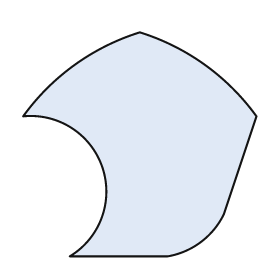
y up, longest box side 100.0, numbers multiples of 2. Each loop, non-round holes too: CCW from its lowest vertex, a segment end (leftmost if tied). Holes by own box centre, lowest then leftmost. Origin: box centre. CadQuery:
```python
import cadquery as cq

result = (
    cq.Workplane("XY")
    .moveTo(-30.0, -48.0)
    .lineTo(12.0, -48.0)
    .threePointArc((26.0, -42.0), (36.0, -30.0))
    .lineTo(50.0, 12.0)
    .threePointArc((28.0, 34.0), (0.0, 48.0))
    .threePointArc((-28.0, 34.0), (-50.0, 12.0))
    .threePointArc((-16.0, -10.0), (-30.0, -48.0))
    .close()
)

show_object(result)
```